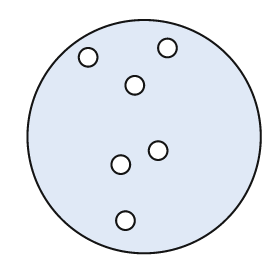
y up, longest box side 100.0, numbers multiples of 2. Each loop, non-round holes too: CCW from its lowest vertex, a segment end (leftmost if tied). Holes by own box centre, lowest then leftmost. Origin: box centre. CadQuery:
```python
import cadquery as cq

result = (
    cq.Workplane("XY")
    .moveTo(0.0, 0.0)
    .circle(50.0)
    .moveTo(-8.0, -36.0)
    .circle(4.0)
    .moveTo(-10.0, -12.0)
    .circle(4.0)
    .moveTo(6.0, -6.0)
    .circle(4.0)
    .moveTo(-4.0, 22.0)
    .circle(4.0)
    .moveTo(-24.0, 34.0)
    .circle(4.0)
    .moveTo(10.0, 38.0)
    .circle(4.0)
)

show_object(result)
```